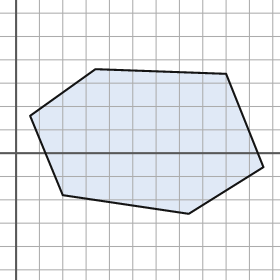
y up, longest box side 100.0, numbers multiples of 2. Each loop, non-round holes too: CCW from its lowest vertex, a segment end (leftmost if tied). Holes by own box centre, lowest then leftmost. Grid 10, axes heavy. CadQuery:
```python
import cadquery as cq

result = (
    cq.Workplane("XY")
    .moveTo(74.0, -26.0)
    .lineTo(106.0, -6.0)
    .lineTo(90.0, 34.0)
    .lineTo(34.0, 36.0)
    .lineTo(6.0, 16.0)
    .lineTo(20.0, -18.0)
    .close()
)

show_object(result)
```